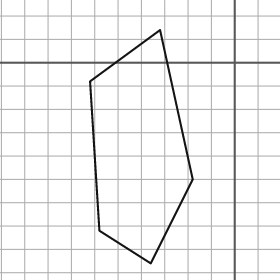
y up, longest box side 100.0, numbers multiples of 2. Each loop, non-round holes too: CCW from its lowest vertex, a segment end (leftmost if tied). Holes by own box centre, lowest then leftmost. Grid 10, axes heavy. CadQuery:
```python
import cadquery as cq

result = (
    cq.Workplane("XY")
    .moveTo(-36.0, -86.0)
    .lineTo(-18.0, -50.0)
    .lineTo(-32.0, 14.0)
    .lineTo(-62.0, -8.0)
    .lineTo(-58.0, -72.0)
    .close()
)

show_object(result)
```